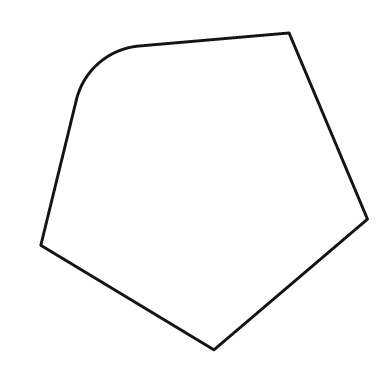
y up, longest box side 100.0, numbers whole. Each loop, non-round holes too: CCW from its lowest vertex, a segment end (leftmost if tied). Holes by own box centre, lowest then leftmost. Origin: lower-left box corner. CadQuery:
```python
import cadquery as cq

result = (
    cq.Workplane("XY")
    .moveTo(53.0, 0.0)
    .lineTo(100.0, 40.0)
    .lineTo(76.0, 97.0)
    .lineTo(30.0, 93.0)
    .threePointArc((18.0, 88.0), (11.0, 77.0))
    .lineTo(0.0, 32.0)
    .close()
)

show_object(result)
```